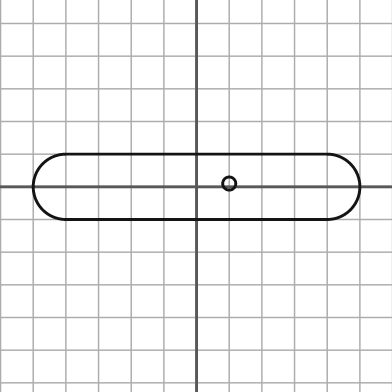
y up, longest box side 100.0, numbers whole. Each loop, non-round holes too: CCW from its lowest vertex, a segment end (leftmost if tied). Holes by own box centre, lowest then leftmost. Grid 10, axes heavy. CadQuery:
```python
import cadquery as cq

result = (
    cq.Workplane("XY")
    .moveTo(-40.0, -10.0)
    .lineTo(40.0, -10.0)
    .threePointArc((50.0, 0.0), (40.0, 10.0))
    .lineTo(-40.0, 10.0)
    .threePointArc((-50.0, 0.0), (-40.0, -10.0))
    .close()
    .moveTo(10.0, 1.0)
    .circle(2.0)
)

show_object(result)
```